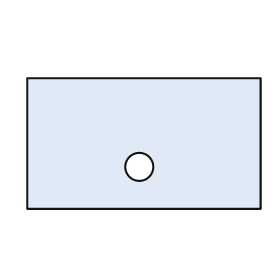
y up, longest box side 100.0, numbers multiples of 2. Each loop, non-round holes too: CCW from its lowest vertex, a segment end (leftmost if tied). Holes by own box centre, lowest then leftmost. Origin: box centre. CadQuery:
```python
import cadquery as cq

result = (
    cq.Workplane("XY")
    .moveTo(-50.0, -28.0)
    .lineTo(50.0, -28.0)
    .lineTo(50.0, 28.0)
    .lineTo(-50.0, 28.0)
    .close()
    .moveTo(-2.0, -10.0)
    .circle(6.0)
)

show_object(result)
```